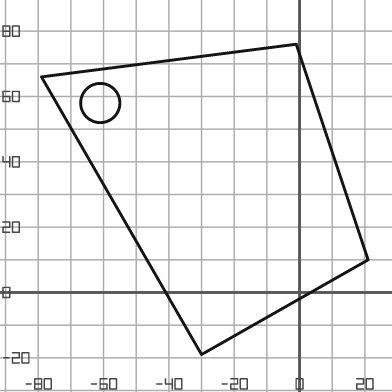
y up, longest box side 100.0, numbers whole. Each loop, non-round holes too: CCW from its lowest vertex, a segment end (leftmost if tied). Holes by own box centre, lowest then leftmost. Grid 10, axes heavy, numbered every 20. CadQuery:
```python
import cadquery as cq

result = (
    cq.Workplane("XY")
    .moveTo(-30.0, -19.0)
    .lineTo(21.0, 10.0)
    .lineTo(-1.0, 76.0)
    .lineTo(-79.0, 66.0)
    .close()
    .moveTo(-61.0, 58.0)
    .circle(6.0)
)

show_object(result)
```